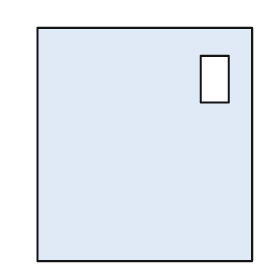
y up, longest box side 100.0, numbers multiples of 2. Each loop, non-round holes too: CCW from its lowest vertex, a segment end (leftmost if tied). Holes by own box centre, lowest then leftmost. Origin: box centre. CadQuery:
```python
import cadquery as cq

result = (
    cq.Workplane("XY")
    .moveTo(-46.0, -50.0)
    .lineTo(46.0, -50.0)
    .lineTo(46.0, 50.0)
    .lineTo(-46.0, 50.0)
    .close()
    .moveTo(24.0, 18.0)
    .lineTo(36.0, 18.0)
    .lineTo(36.0, 38.0)
    .lineTo(24.0, 38.0)
    .close()
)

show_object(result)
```